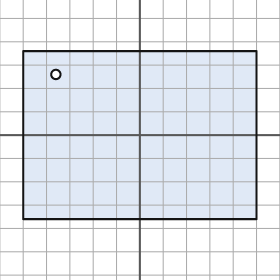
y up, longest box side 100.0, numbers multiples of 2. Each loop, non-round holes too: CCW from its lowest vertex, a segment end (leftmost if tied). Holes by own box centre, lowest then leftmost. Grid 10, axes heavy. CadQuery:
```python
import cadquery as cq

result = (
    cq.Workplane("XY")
    .moveTo(-50.0, -36.0)
    .lineTo(50.0, -36.0)
    .lineTo(50.0, 36.0)
    .lineTo(-50.0, 36.0)
    .close()
    .moveTo(-36.0, 26.0)
    .circle(2.0)
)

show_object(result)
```